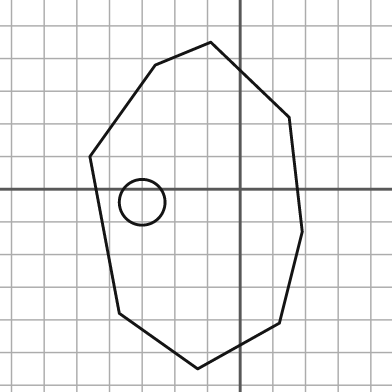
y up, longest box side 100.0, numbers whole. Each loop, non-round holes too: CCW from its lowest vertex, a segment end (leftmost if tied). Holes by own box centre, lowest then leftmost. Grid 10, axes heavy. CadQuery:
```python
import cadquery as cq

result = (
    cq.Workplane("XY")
    .moveTo(-13.0, -55.0)
    .lineTo(12.0, -41.0)
    .lineTo(19.0, -13.0)
    .lineTo(15.0, 22.0)
    .lineTo(-9.0, 45.0)
    .lineTo(-26.0, 38.0)
    .lineTo(-46.0, 10.0)
    .lineTo(-37.0, -38.0)
    .close()
    .moveTo(-30.0, -4.0)
    .circle(7.0)
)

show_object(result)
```